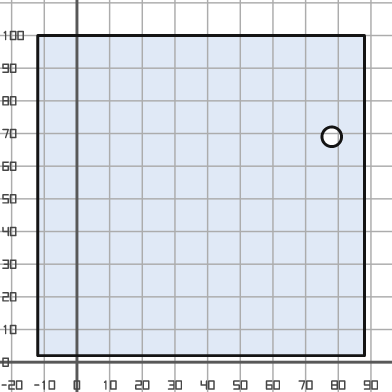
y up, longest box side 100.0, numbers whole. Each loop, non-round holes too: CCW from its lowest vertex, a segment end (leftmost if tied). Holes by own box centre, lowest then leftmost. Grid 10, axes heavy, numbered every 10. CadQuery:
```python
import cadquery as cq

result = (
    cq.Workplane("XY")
    .moveTo(-12.0, 2.0)
    .lineTo(88.0, 2.0)
    .lineTo(88.0, 100.0)
    .lineTo(-12.0, 100.0)
    .close()
    .moveTo(78.0, 69.0)
    .circle(3.0)
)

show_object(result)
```